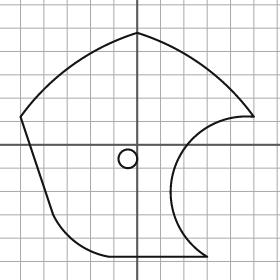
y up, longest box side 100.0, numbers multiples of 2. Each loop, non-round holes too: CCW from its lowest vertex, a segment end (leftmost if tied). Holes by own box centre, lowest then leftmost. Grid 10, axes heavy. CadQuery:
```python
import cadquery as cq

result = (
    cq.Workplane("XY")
    .moveTo(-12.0, -48.0)
    .lineTo(30.0, -48.0)
    .threePointArc((16.0, -10.0), (50.0, 12.0))
    .threePointArc((28.0, 34.0), (0.0, 48.0))
    .threePointArc((-28.0, 34.0), (-50.0, 12.0))
    .lineTo(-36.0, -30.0)
    .threePointArc((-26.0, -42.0), (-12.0, -48.0))
    .close()
    .moveTo(-4.0, -6.0)
    .circle(4.0)
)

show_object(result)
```